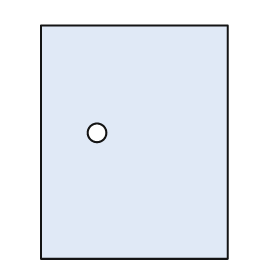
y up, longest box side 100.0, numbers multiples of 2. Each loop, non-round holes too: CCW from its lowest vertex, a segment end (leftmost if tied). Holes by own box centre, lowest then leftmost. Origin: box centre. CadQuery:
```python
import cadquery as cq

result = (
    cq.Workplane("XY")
    .moveTo(-40.0, -50.0)
    .lineTo(40.0, -50.0)
    .lineTo(40.0, 50.0)
    .lineTo(-40.0, 50.0)
    .close()
    .moveTo(-16.0, 4.0)
    .circle(4.0)
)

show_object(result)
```